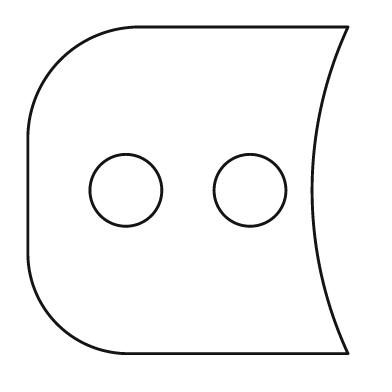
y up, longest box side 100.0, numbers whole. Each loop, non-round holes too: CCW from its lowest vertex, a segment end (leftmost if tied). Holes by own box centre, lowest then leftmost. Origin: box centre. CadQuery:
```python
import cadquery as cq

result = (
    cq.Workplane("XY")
    .moveTo(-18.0, -50.0)
    .lineTo(49.0, -50.0)
    .threePointArc((38.0, 0.0), (49.0, 50.0))
    .lineTo(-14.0, 50.0)
    .threePointArc((-39.0, 40.0), (-49.0, 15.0))
    .lineTo(-49.0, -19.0)
    .threePointArc((-40.0, -41.0), (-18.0, -50.0))
    .close()
    .moveTo(-19.0, 0.0)
    .circle(11.0)
    .moveTo(19.0, 0.0)
    .circle(11.0)
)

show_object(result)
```